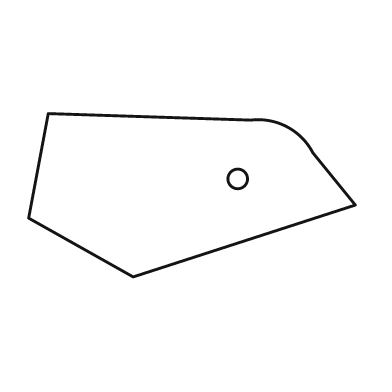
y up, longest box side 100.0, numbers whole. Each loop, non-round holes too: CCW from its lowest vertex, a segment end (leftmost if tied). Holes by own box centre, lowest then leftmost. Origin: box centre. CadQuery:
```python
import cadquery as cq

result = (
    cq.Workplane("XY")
    .moveTo(-18.0, -25.0)
    .lineTo(50.0, -3.0)
    .lineTo(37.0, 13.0)
    .threePointArc((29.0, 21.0), (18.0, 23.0))
    .lineTo(-44.0, 25.0)
    .lineTo(-50.0, -7.0)
    .close()
    .moveTo(14.0, 5.0)
    .circle(3.0)
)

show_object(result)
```